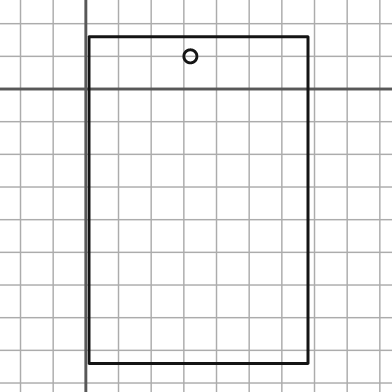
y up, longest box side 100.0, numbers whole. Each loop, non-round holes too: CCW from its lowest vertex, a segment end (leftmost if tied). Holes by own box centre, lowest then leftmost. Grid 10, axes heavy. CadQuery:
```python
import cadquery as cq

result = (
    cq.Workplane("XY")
    .moveTo(1.0, -84.0)
    .lineTo(68.0, -84.0)
    .lineTo(68.0, 16.0)
    .lineTo(1.0, 16.0)
    .close()
    .moveTo(32.0, 10.0)
    .circle(2.0)
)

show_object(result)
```